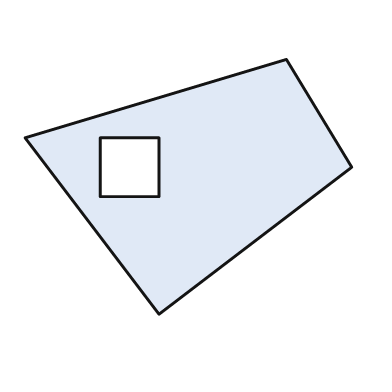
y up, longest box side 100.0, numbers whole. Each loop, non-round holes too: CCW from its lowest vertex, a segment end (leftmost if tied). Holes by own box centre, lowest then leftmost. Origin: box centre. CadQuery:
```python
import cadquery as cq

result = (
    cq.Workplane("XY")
    .moveTo(-9.0, -39.0)
    .lineTo(50.0, 6.0)
    .lineTo(30.0, 39.0)
    .lineTo(-50.0, 15.0)
    .close()
    .moveTo(-27.0, -3.0)
    .lineTo(-9.0, -3.0)
    .lineTo(-9.0, 15.0)
    .lineTo(-27.0, 15.0)
    .close()
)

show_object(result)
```